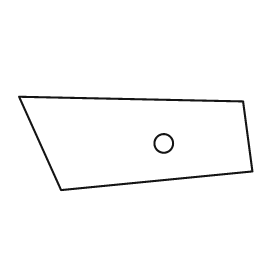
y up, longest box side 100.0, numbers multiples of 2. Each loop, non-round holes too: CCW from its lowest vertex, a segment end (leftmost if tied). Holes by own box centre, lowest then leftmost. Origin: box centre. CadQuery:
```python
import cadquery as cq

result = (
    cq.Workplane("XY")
    .moveTo(-32.0, -20.0)
    .lineTo(50.0, -12.0)
    .lineTo(46.0, 18.0)
    .lineTo(-50.0, 20.0)
    .close()
    .moveTo(12.0, 0.0)
    .circle(4.0)
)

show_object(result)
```